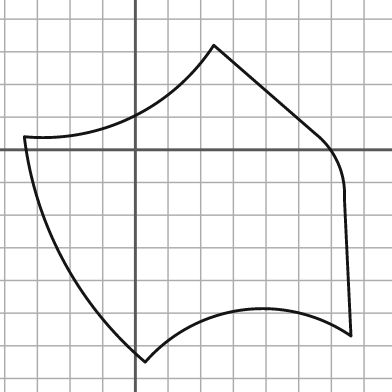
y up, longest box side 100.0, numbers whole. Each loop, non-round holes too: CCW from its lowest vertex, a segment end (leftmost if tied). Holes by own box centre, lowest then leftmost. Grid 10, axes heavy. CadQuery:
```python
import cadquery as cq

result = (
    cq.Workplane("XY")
    .moveTo(3.0, -65.0)
    .threePointArc((33.0, -49.0), (66.0, -57.0))
    .lineTo(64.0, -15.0)
    .threePointArc((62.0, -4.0), (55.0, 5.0))
    .lineTo(24.0, 32.0)
    .threePointArc((-1.0, 10.0), (-34.0, 4.0))
    .threePointArc((-22.0, -34.0), (3.0, -65.0))
    .close()
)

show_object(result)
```